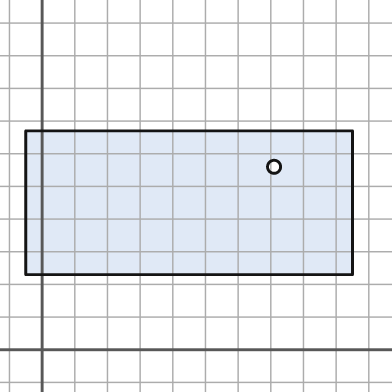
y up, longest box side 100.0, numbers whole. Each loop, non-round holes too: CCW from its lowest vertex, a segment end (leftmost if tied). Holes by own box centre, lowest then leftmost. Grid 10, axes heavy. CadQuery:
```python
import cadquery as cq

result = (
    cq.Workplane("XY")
    .moveTo(-5.0, 23.0)
    .lineTo(95.0, 23.0)
    .lineTo(95.0, 67.0)
    .lineTo(-5.0, 67.0)
    .close()
    .moveTo(71.0, 56.0)
    .circle(2.0)
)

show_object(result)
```